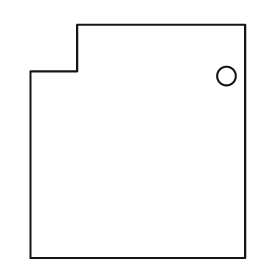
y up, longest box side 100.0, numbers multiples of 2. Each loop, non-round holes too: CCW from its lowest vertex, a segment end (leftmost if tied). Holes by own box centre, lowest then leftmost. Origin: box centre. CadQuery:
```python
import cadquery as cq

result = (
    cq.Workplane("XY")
    .moveTo(-46.0, -50.0)
    .lineTo(46.0, -50.0)
    .lineTo(46.0, 50.0)
    .lineTo(-26.0, 50.0)
    .lineTo(-26.0, 30.0)
    .lineTo(-46.0, 30.0)
    .close()
    .moveTo(38.0, 28.0)
    .circle(4.0)
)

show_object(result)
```